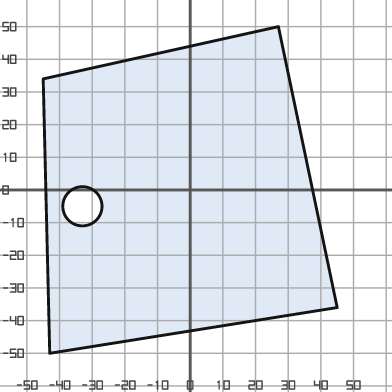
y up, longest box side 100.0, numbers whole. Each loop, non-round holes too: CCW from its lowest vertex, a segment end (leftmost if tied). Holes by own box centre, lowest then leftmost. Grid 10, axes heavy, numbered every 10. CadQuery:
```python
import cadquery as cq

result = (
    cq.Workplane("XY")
    .moveTo(-43.0, -50.0)
    .lineTo(45.0, -36.0)
    .lineTo(27.0, 50.0)
    .lineTo(-45.0, 34.0)
    .close()
    .moveTo(-33.0, -5.0)
    .circle(6.0)
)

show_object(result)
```